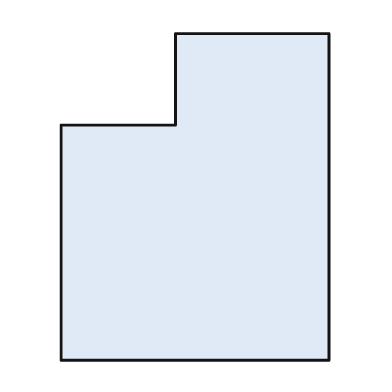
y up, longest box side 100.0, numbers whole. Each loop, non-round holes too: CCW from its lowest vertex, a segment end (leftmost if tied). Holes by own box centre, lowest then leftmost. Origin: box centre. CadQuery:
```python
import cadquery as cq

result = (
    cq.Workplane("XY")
    .moveTo(-41.0, -50.0)
    .lineTo(41.0, -50.0)
    .lineTo(41.0, 50.0)
    .lineTo(-6.0, 50.0)
    .lineTo(-6.0, 22.0)
    .lineTo(-41.0, 22.0)
    .close()
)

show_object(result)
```